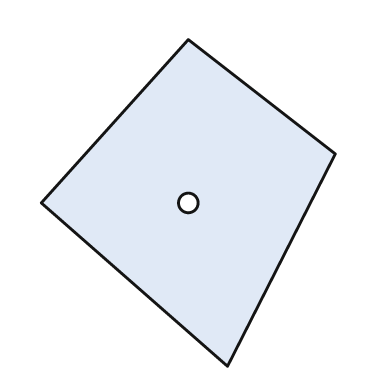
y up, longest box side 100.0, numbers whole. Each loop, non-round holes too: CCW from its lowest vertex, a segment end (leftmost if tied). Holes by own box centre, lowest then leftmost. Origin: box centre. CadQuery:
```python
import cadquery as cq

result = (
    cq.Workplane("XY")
    .moveTo(12.0, -50.0)
    .lineTo(45.0, 15.0)
    .lineTo(0.0, 50.0)
    .lineTo(-45.0, 0.0)
    .close()
    .moveTo(0.0, 0.0)
    .circle(3.0)
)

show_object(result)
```